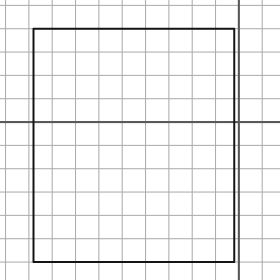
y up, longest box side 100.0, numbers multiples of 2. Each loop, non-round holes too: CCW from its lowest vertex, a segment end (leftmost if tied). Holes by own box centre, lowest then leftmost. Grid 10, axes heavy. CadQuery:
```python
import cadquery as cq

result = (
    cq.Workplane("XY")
    .moveTo(-88.0, -60.0)
    .lineTo(-2.0, -60.0)
    .lineTo(-2.0, 40.0)
    .lineTo(-88.0, 40.0)
    .close()
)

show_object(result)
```